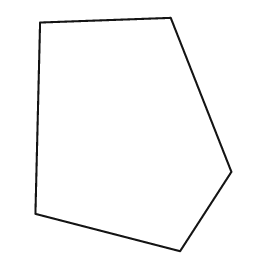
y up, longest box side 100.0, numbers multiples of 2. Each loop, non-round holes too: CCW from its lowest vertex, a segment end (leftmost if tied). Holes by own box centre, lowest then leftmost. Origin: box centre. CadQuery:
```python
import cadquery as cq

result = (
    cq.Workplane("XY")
    .moveTo(20.0, -50.0)
    .lineTo(42.0, -16.0)
    .lineTo(16.0, 50.0)
    .lineTo(-40.0, 48.0)
    .lineTo(-42.0, -34.0)
    .close()
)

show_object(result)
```